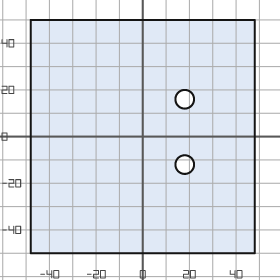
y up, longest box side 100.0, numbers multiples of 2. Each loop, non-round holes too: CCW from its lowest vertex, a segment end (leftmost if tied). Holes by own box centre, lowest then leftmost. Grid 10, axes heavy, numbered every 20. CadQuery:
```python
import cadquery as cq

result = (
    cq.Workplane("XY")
    .moveTo(-48.0, -50.0)
    .lineTo(48.0, -50.0)
    .lineTo(48.0, 50.0)
    .lineTo(-48.0, 50.0)
    .close()
    .moveTo(18.0, -12.0)
    .circle(4.0)
    .moveTo(18.0, 16.0)
    .circle(4.0)
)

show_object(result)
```